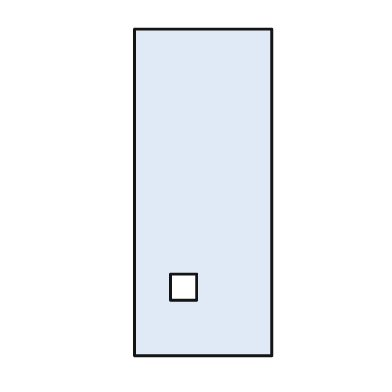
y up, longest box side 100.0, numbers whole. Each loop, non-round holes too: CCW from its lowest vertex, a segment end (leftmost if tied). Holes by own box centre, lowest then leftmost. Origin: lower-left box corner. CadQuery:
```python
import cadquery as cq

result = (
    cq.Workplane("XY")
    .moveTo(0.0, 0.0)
    .lineTo(42.0, 0.0)
    .lineTo(42.0, 100.0)
    .lineTo(0.0, 100.0)
    .close()
    .moveTo(11.0, 17.0)
    .lineTo(19.0, 17.0)
    .lineTo(19.0, 25.0)
    .lineTo(11.0, 25.0)
    .close()
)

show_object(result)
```